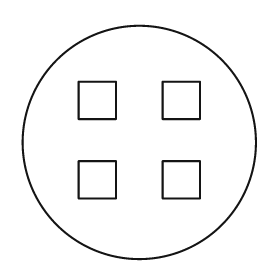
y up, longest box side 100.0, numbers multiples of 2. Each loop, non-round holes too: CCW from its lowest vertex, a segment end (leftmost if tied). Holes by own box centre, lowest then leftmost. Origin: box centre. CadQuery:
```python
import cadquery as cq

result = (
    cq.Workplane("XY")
    .moveTo(0.0, 0.0)
    .circle(50.0)
    .moveTo(-26.0, -24.0)
    .lineTo(-10.0, -24.0)
    .lineTo(-10.0, -8.0)
    .lineTo(-26.0, -8.0)
    .close()
    .moveTo(10.0, -24.0)
    .lineTo(26.0, -24.0)
    .lineTo(26.0, -8.0)
    .lineTo(10.0, -8.0)
    .close()
    .moveTo(-26.0, 10.0)
    .lineTo(-10.0, 10.0)
    .lineTo(-10.0, 26.0)
    .lineTo(-26.0, 26.0)
    .close()
    .moveTo(10.0, 10.0)
    .lineTo(26.0, 10.0)
    .lineTo(26.0, 26.0)
    .lineTo(10.0, 26.0)
    .close()
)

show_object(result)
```